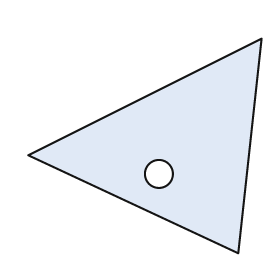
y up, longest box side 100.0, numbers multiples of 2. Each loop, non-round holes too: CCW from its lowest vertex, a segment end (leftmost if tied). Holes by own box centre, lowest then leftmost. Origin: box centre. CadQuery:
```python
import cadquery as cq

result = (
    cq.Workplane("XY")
    .moveTo(40.0, -46.0)
    .lineTo(50.0, 46.0)
    .lineTo(-50.0, -4.0)
    .close()
    .moveTo(6.0, -12.0)
    .circle(6.0)
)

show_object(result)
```